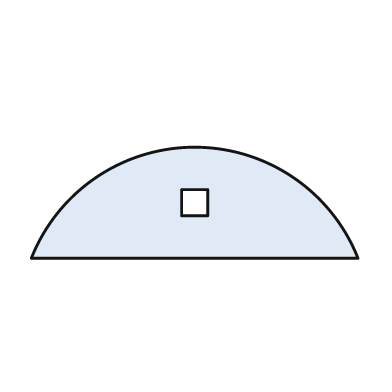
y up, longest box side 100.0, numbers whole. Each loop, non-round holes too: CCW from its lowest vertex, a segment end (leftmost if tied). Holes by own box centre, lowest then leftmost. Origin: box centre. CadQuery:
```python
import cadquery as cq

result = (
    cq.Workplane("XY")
    .moveTo(-50.0, -17.0)
    .lineTo(50.0, -17.0)
    .threePointArc((0.0, 17.0), (-50.0, -17.0))
    .close()
    .moveTo(-4.0, -4.0)
    .lineTo(4.0, -4.0)
    .lineTo(4.0, 4.0)
    .lineTo(-4.0, 4.0)
    .close()
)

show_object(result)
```